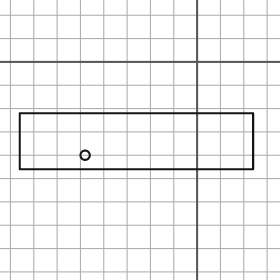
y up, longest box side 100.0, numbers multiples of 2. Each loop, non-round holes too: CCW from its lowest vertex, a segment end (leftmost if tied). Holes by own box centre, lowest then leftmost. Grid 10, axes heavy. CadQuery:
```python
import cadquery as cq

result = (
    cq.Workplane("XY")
    .moveTo(-76.0, -46.0)
    .lineTo(24.0, -46.0)
    .lineTo(24.0, -22.0)
    .lineTo(-76.0, -22.0)
    .close()
    .moveTo(-48.0, -40.0)
    .circle(2.0)
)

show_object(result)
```